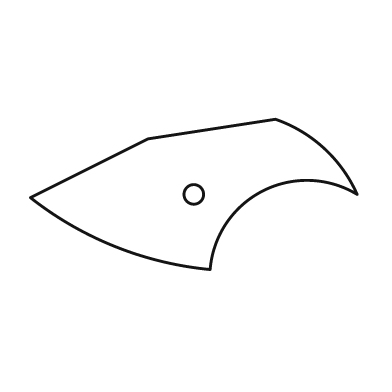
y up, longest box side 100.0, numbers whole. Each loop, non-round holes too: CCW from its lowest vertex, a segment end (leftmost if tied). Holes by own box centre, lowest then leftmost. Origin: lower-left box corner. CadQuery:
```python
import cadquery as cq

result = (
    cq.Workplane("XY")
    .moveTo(55.0, 0.0)
    .threePointArc((71.0, 24.0), (100.0, 23.0))
    .threePointArc((90.0, 37.0), (75.0, 46.0))
    .lineTo(36.0, 40.0)
    .lineTo(0.0, 22.0)
    .threePointArc((26.0, 7.0), (55.0, 0.0))
    .close()
    .moveTo(50.0, 23.0)
    .circle(3.0)
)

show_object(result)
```